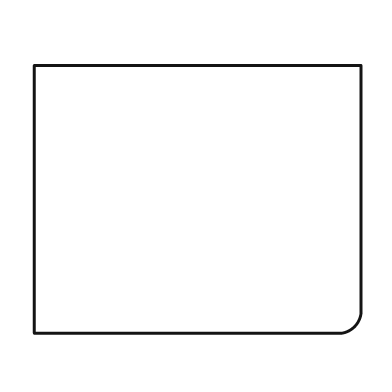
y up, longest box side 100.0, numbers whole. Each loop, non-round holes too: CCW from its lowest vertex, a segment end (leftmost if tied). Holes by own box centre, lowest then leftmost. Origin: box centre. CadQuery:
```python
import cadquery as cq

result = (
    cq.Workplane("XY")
    .moveTo(-50.0, -41.0)
    .lineTo(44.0, -41.0)
    .threePointArc((48.0, -39.0), (50.0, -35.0))
    .lineTo(50.0, 41.0)
    .lineTo(-50.0, 41.0)
    .close()
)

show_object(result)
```